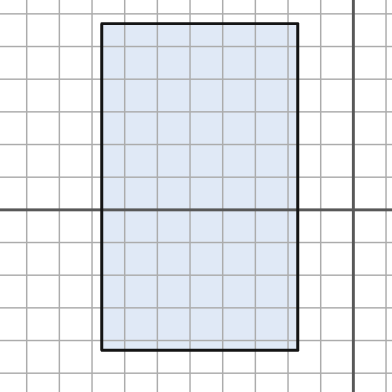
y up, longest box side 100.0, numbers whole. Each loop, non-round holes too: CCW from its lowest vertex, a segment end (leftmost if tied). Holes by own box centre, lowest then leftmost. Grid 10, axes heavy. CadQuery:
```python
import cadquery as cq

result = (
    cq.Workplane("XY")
    .moveTo(-77.0, -43.0)
    .lineTo(-17.0, -43.0)
    .lineTo(-17.0, 57.0)
    .lineTo(-77.0, 57.0)
    .close()
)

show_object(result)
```